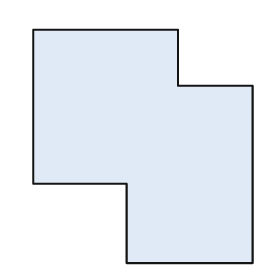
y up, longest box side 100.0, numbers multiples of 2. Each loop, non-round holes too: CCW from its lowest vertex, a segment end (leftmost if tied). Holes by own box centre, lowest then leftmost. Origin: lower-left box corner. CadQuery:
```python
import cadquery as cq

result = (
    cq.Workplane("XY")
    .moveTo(40.0, 0.0)
    .lineTo(94.0, 0.0)
    .lineTo(94.0, 76.0)
    .lineTo(62.0, 76.0)
    .lineTo(62.0, 100.0)
    .lineTo(0.0, 100.0)
    .lineTo(0.0, 34.0)
    .lineTo(40.0, 34.0)
    .close()
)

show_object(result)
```